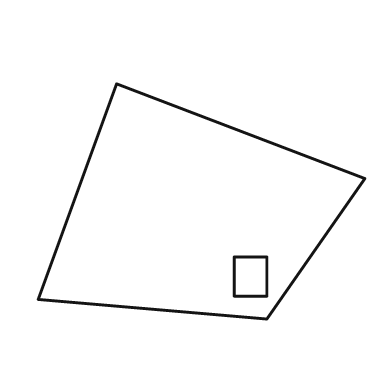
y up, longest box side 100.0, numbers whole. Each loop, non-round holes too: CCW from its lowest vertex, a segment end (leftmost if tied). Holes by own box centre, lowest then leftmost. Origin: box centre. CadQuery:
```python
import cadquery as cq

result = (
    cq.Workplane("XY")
    .moveTo(20.0, -36.0)
    .lineTo(50.0, 7.0)
    .lineTo(-26.0, 36.0)
    .lineTo(-50.0, -30.0)
    .close()
    .moveTo(10.0, -29.0)
    .lineTo(20.0, -29.0)
    .lineTo(20.0, -17.0)
    .lineTo(10.0, -17.0)
    .close()
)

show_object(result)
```